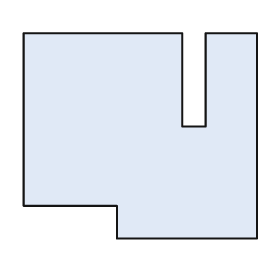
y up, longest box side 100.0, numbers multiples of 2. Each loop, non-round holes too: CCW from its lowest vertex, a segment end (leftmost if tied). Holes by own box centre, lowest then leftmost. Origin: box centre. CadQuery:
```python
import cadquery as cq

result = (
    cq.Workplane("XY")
    .moveTo(-10.0, -44.0)
    .lineTo(50.0, -44.0)
    .lineTo(50.0, 44.0)
    .lineTo(28.0, 44.0)
    .lineTo(28.0, 4.0)
    .lineTo(18.0, 4.0)
    .lineTo(18.0, 44.0)
    .lineTo(-50.0, 44.0)
    .lineTo(-50.0, -30.0)
    .lineTo(-10.0, -30.0)
    .close()
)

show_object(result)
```